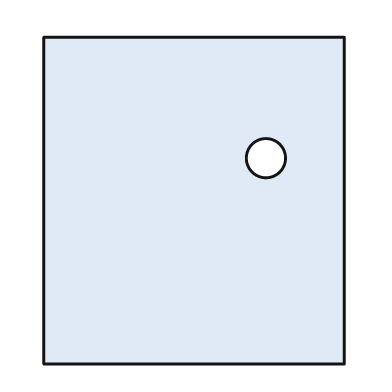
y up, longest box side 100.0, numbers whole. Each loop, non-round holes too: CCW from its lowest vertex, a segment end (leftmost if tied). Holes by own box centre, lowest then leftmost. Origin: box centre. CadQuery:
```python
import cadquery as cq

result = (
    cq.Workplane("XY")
    .moveTo(-46.0, -50.0)
    .lineTo(46.0, -50.0)
    .lineTo(46.0, 50.0)
    .lineTo(-46.0, 50.0)
    .close()
    .moveTo(22.0, 13.0)
    .circle(6.0)
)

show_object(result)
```